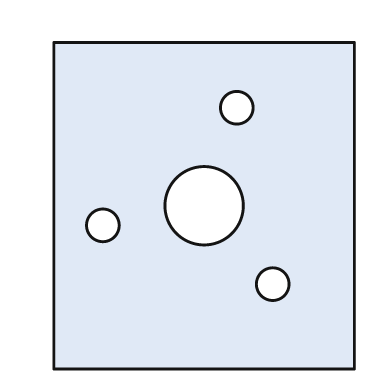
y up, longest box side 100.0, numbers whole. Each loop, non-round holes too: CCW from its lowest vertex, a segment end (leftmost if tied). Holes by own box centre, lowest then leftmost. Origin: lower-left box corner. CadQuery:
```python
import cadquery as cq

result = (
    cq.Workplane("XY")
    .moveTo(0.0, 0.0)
    .lineTo(92.0, 0.0)
    .lineTo(92.0, 100.0)
    .lineTo(0.0, 100.0)
    .close()
    .moveTo(67.0, 26.0)
    .circle(5.0)
    .moveTo(15.0, 44.0)
    .circle(5.0)
    .moveTo(46.0, 50.0)
    .circle(12.0)
    .moveTo(56.0, 80.0)
    .circle(5.0)
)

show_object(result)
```